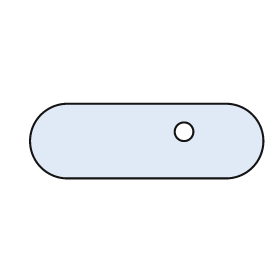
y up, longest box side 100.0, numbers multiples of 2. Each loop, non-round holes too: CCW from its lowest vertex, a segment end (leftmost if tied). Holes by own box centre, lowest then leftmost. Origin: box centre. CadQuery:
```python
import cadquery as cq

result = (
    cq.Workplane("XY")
    .moveTo(-34.0, -16.0)
    .lineTo(34.0, -16.0)
    .threePointArc((50.0, 0.0), (34.0, 16.0))
    .lineTo(-34.0, 16.0)
    .threePointArc((-50.0, 0.0), (-34.0, -16.0))
    .close()
    .moveTo(16.0, 4.0)
    .circle(4.0)
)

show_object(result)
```